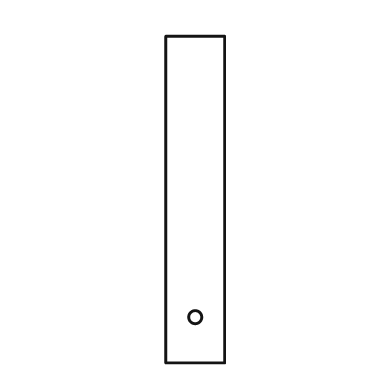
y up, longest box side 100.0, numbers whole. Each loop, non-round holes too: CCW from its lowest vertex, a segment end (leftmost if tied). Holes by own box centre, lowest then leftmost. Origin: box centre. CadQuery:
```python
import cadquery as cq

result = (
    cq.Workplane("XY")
    .moveTo(-9.0, -50.0)
    .lineTo(9.0, -50.0)
    .lineTo(9.0, 50.0)
    .lineTo(-9.0, 50.0)
    .close()
    .moveTo(0.0, -36.0)
    .circle(2.0)
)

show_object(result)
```